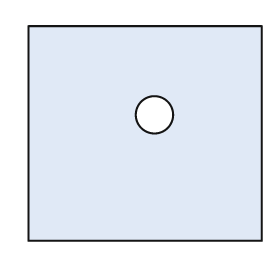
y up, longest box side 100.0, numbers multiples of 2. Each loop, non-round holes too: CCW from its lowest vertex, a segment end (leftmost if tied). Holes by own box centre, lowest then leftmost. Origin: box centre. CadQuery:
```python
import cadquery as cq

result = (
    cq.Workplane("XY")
    .moveTo(-50.0, -46.0)
    .lineTo(50.0, -46.0)
    .lineTo(50.0, 46.0)
    .lineTo(-50.0, 46.0)
    .close()
    .moveTo(4.0, 8.0)
    .circle(8.0)
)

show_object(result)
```